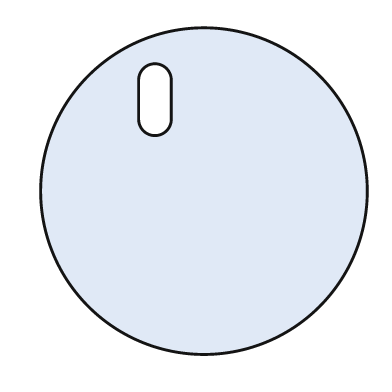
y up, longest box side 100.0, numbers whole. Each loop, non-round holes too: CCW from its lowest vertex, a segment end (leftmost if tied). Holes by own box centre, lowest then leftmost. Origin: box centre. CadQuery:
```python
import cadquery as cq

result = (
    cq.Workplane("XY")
    .moveTo(0.0, 0.0)
    .circle(50.0)
    .moveTo(-20.0, 22.0)
    .threePointArc((-15.0, 17.0), (-10.0, 22.0))
    .lineTo(-10.0, 34.0)
    .threePointArc((-15.0, 39.0), (-20.0, 34.0))
    .close()
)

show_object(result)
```